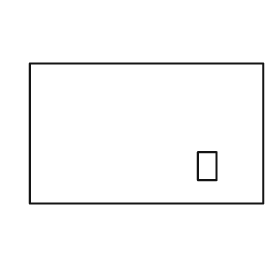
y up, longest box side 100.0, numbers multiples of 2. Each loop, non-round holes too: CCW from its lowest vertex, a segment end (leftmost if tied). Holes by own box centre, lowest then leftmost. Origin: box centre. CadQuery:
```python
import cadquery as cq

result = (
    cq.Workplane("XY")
    .moveTo(-50.0, -30.0)
    .lineTo(50.0, -30.0)
    .lineTo(50.0, 30.0)
    .lineTo(-50.0, 30.0)
    .close()
    .moveTo(22.0, -20.0)
    .lineTo(30.0, -20.0)
    .lineTo(30.0, -8.0)
    .lineTo(22.0, -8.0)
    .close()
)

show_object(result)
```